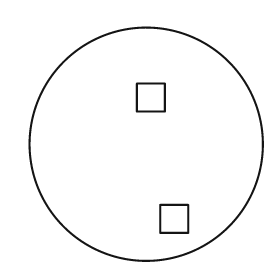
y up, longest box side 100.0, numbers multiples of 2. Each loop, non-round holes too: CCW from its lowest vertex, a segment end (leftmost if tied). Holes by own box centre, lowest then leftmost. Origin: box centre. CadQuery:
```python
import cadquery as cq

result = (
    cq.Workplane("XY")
    .moveTo(0.0, 0.0)
    .circle(50.0)
    .moveTo(6.0, -38.0)
    .lineTo(18.0, -38.0)
    .lineTo(18.0, -26.0)
    .lineTo(6.0, -26.0)
    .close()
    .moveTo(-4.0, 14.0)
    .lineTo(8.0, 14.0)
    .lineTo(8.0, 26.0)
    .lineTo(-4.0, 26.0)
    .close()
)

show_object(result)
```